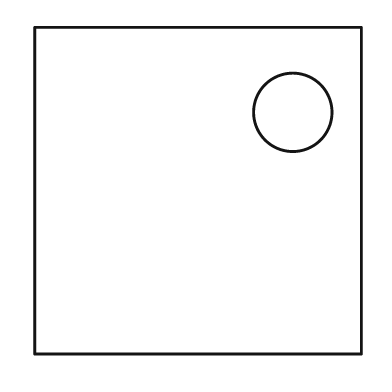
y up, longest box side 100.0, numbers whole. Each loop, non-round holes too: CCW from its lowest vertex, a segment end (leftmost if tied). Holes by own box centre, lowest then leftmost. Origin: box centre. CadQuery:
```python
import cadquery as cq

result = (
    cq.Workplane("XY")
    .moveTo(-50.0, -50.0)
    .lineTo(50.0, -50.0)
    .lineTo(50.0, 50.0)
    .lineTo(-50.0, 50.0)
    .close()
    .moveTo(29.0, 24.0)
    .circle(12.0)
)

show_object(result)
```